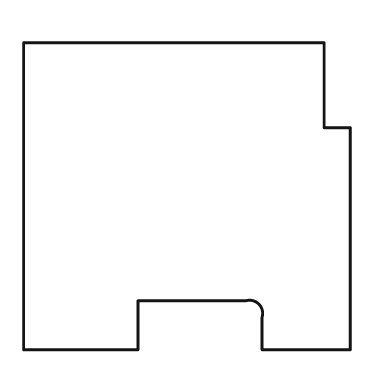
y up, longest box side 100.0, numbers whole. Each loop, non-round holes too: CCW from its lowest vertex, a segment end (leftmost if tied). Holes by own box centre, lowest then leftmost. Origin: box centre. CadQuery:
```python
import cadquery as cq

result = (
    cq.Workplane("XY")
    .moveTo(-50.0, -47.0)
    .lineTo(-15.0, -47.0)
    .lineTo(-15.0, -32.0)
    .lineTo(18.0, -32.0)
    .threePointArc((22.0, -33.0), (23.0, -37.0))
    .lineTo(23.0, -47.0)
    .lineTo(50.0, -47.0)
    .lineTo(50.0, 21.0)
    .lineTo(42.0, 21.0)
    .lineTo(42.0, 47.0)
    .lineTo(-50.0, 47.0)
    .close()
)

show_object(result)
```